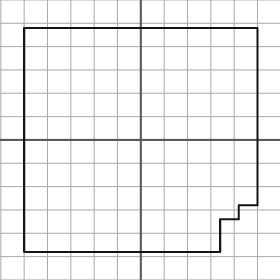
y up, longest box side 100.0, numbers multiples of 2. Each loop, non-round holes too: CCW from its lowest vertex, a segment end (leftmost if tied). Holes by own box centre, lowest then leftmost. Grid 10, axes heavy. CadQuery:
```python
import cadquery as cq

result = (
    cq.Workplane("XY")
    .moveTo(-50.0, -48.0)
    .lineTo(34.0, -48.0)
    .lineTo(34.0, -34.0)
    .lineTo(42.0, -34.0)
    .lineTo(42.0, -28.0)
    .lineTo(50.0, -28.0)
    .lineTo(50.0, 48.0)
    .lineTo(-50.0, 48.0)
    .close()
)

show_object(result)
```